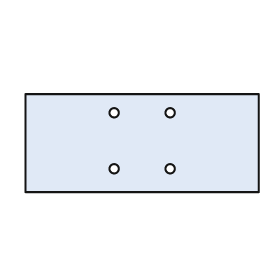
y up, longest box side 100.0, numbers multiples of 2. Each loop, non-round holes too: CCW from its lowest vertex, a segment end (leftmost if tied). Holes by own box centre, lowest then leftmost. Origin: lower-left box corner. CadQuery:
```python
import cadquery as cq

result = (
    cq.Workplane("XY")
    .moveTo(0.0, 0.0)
    .lineTo(100.0, 0.0)
    .lineTo(100.0, 42.0)
    .lineTo(0.0, 42.0)
    .close()
    .moveTo(38.0, 10.0)
    .circle(2.0)
    .moveTo(62.0, 10.0)
    .circle(2.0)
    .moveTo(38.0, 34.0)
    .circle(2.0)
    .moveTo(62.0, 34.0)
    .circle(2.0)
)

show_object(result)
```